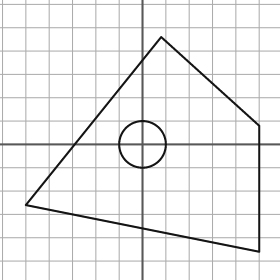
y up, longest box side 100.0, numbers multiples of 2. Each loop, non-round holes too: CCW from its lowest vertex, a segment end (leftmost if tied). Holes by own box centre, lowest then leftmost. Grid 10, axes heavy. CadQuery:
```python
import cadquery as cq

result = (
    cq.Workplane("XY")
    .moveTo(50.0, -46.0)
    .lineTo(50.0, 8.0)
    .lineTo(8.0, 46.0)
    .lineTo(-50.0, -26.0)
    .close()
    .moveTo(0.0, 0.0)
    .circle(10.0)
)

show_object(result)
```